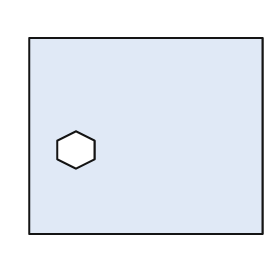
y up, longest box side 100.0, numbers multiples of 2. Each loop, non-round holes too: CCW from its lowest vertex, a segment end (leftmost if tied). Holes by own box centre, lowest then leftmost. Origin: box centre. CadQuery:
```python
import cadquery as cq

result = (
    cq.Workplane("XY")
    .moveTo(-50.0, -42.0)
    .lineTo(50.0, -42.0)
    .lineTo(50.0, 42.0)
    .lineTo(-50.0, 42.0)
    .close()
    .moveTo(-30.0, -14.0)
    .lineTo(-22.0, -10.0)
    .lineTo(-22.0, -2.0)
    .lineTo(-30.0, 2.0)
    .lineTo(-38.0, -2.0)
    .lineTo(-38.0, -10.0)
    .close()
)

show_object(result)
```